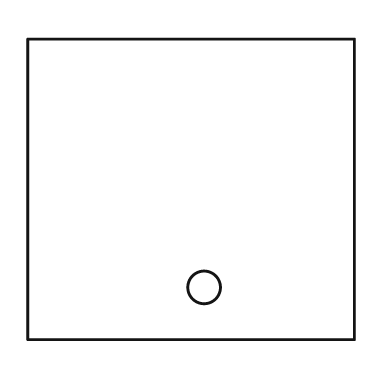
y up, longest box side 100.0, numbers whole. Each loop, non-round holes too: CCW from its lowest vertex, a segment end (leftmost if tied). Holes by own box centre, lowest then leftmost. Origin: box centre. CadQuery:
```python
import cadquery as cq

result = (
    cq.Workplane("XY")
    .moveTo(-50.0, -46.0)
    .lineTo(50.0, -46.0)
    .lineTo(50.0, 46.0)
    .lineTo(-50.0, 46.0)
    .close()
    .moveTo(4.0, -30.0)
    .circle(5.0)
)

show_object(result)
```